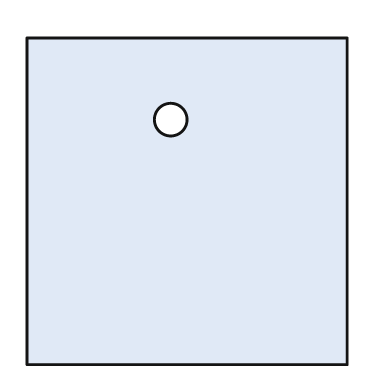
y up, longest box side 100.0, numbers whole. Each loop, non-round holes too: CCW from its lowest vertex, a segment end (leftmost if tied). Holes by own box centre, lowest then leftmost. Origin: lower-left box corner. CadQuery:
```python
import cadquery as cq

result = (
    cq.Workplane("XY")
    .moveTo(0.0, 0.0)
    .lineTo(98.0, 0.0)
    .lineTo(98.0, 100.0)
    .lineTo(0.0, 100.0)
    .close()
    .moveTo(44.0, 75.0)
    .circle(5.0)
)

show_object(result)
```